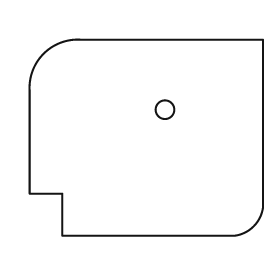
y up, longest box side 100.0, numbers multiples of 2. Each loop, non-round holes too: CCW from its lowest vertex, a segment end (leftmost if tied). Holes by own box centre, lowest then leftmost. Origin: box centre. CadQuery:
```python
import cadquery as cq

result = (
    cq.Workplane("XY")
    .moveTo(-36.0, -42.0)
    .lineTo(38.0, -42.0)
    .threePointArc((46.0, -38.0), (50.0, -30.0))
    .lineTo(50.0, 42.0)
    .lineTo(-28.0, 42.0)
    .threePointArc((-44.0, 36.0), (-50.0, 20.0))
    .lineTo(-50.0, -24.0)
    .lineTo(-36.0, -24.0)
    .close()
    .moveTo(8.0, 12.0)
    .circle(4.0)
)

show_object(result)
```